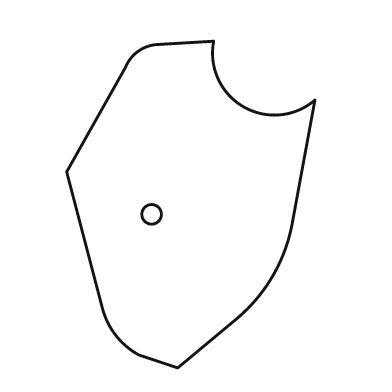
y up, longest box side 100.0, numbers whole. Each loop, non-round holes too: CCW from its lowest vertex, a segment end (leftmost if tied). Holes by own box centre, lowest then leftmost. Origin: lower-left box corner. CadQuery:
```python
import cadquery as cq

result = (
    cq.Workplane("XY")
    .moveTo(34.0, 0.0)
    .lineTo(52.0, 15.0)
    .threePointArc((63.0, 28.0), (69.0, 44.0))
    .lineTo(76.0, 82.0)
    .threePointArc((54.0, 80.0), (45.0, 100.0))
    .lineTo(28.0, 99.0)
    .threePointArc((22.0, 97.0), (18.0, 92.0))
    .lineTo(0.0, 60.0)
    .lineTo(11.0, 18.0)
    .threePointArc((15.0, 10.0), (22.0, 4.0))
    .close()
    .moveTo(26.0, 47.0)
    .circle(3.0)
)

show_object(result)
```